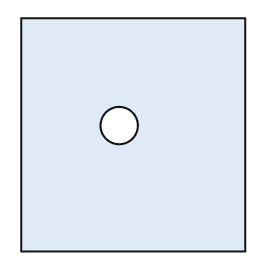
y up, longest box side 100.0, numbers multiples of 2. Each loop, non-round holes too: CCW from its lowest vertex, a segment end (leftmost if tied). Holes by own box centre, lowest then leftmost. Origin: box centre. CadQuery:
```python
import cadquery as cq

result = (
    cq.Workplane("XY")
    .moveTo(-48.0, -50.0)
    .lineTo(48.0, -50.0)
    .lineTo(48.0, 50.0)
    .lineTo(-48.0, 50.0)
    .close()
    .moveTo(-6.0, 4.0)
    .circle(8.0)
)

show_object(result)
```